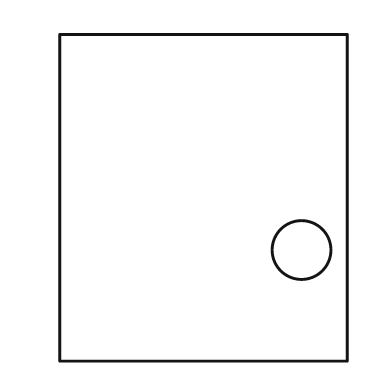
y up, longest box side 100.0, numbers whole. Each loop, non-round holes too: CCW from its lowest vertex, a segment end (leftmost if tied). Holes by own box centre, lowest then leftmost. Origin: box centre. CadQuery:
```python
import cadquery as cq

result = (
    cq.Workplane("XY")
    .moveTo(-44.0, -50.0)
    .lineTo(44.0, -50.0)
    .lineTo(44.0, 50.0)
    .lineTo(-44.0, 50.0)
    .close()
    .moveTo(30.0, -16.0)
    .circle(9.0)
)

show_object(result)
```